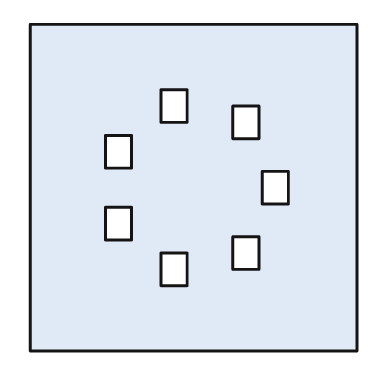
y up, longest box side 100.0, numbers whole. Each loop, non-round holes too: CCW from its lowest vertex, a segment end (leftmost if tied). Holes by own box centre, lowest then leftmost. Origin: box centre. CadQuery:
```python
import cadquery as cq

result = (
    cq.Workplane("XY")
    .moveTo(-50.0, -50.0)
    .lineTo(50.0, -50.0)
    .lineTo(50.0, 50.0)
    .lineTo(-50.0, 50.0)
    .close()
    .moveTo(-10.0, -30.0)
    .lineTo(-2.0, -30.0)
    .lineTo(-2.0, -20.0)
    .lineTo(-10.0, -20.0)
    .close()
    .moveTo(12.0, -25.0)
    .lineTo(20.0, -25.0)
    .lineTo(20.0, -15.0)
    .lineTo(12.0, -15.0)
    .close()
    .moveTo(-27.0, -16.0)
    .lineTo(-19.0, -16.0)
    .lineTo(-19.0, -6.0)
    .lineTo(-27.0, -6.0)
    .close()
    .moveTo(21.0, -5.0)
    .lineTo(29.0, -5.0)
    .lineTo(29.0, 5.0)
    .lineTo(21.0, 5.0)
    .close()
    .moveTo(-27.0, 6.0)
    .lineTo(-19.0, 6.0)
    .lineTo(-19.0, 16.0)
    .lineTo(-27.0, 16.0)
    .close()
    .moveTo(12.0, 15.0)
    .lineTo(20.0, 15.0)
    .lineTo(20.0, 25.0)
    .lineTo(12.0, 25.0)
    .close()
    .moveTo(-10.0, 20.0)
    .lineTo(-2.0, 20.0)
    .lineTo(-2.0, 30.0)
    .lineTo(-10.0, 30.0)
    .close()
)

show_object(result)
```